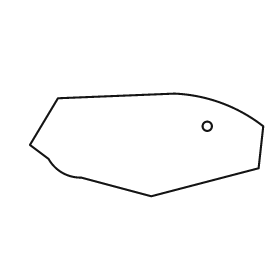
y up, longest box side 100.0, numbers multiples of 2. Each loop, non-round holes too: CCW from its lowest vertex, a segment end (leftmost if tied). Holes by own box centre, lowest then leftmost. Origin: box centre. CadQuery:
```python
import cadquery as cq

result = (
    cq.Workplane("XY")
    .moveTo(2.0, -22.0)
    .lineTo(48.0, -10.0)
    .lineTo(50.0, 8.0)
    .threePointArc((32.0, 18.0), (12.0, 22.0))
    .lineTo(-38.0, 20.0)
    .lineTo(-50.0, 0.0)
    .lineTo(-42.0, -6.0)
    .threePointArc((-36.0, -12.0), (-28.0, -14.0))
    .close()
    .moveTo(26.0, 8.0)
    .circle(2.0)
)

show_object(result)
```